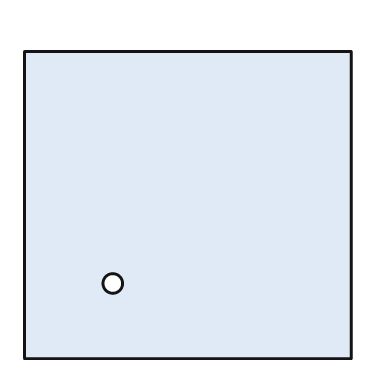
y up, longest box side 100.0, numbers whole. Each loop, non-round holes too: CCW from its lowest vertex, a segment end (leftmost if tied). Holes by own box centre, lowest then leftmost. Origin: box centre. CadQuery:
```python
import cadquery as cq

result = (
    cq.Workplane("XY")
    .moveTo(-50.0, -47.0)
    .lineTo(50.0, -47.0)
    .lineTo(50.0, 47.0)
    .lineTo(-50.0, 47.0)
    .close()
    .moveTo(-23.0, -24.0)
    .circle(3.0)
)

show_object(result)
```